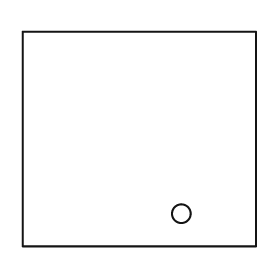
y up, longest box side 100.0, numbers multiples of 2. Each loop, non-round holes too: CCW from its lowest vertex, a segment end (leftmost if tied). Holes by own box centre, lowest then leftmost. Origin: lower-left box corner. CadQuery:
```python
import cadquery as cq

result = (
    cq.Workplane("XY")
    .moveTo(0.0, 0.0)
    .lineTo(100.0, 0.0)
    .lineTo(100.0, 92.0)
    .lineTo(0.0, 92.0)
    .close()
    .moveTo(68.0, 14.0)
    .circle(4.0)
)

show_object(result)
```